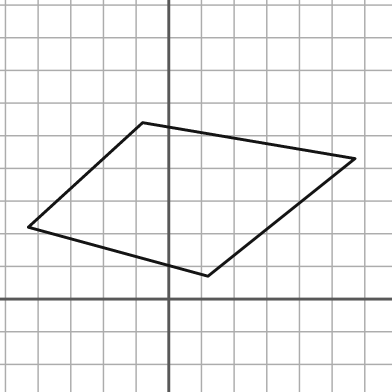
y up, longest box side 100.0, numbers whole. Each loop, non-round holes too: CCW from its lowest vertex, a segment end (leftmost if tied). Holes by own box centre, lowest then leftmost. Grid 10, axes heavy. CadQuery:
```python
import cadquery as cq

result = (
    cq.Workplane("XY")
    .moveTo(12.0, 7.0)
    .lineTo(57.0, 43.0)
    .lineTo(-8.0, 54.0)
    .lineTo(-43.0, 22.0)
    .close()
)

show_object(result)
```